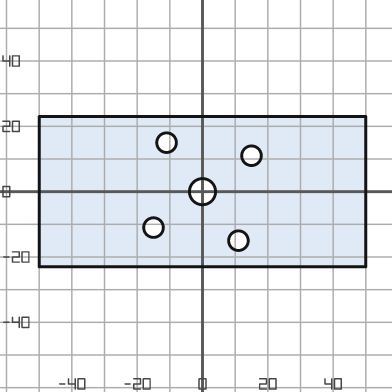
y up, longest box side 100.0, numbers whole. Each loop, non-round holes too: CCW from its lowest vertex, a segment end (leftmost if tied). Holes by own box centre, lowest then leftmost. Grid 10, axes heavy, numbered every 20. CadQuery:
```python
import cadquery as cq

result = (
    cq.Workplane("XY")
    .moveTo(-50.0, -23.0)
    .lineTo(50.0, -23.0)
    .lineTo(50.0, 23.0)
    .lineTo(-50.0, 23.0)
    .close()
    .moveTo(11.0, -15.0)
    .circle(3.0)
    .moveTo(-15.0, -11.0)
    .circle(3.0)
    .moveTo(0.0, 0.0)
    .circle(4.0)
    .moveTo(15.0, 11.0)
    .circle(3.0)
    .moveTo(-11.0, 15.0)
    .circle(3.0)
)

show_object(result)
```